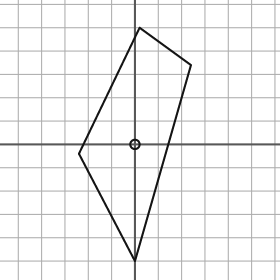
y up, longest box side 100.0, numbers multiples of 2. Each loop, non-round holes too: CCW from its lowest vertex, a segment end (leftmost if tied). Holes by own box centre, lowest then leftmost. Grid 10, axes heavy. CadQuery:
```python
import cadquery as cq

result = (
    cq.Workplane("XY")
    .moveTo(0.0, -50.0)
    .lineTo(24.0, 34.0)
    .lineTo(2.0, 50.0)
    .lineTo(-24.0, -4.0)
    .close()
    .moveTo(0.0, 0.0)
    .circle(2.0)
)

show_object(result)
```